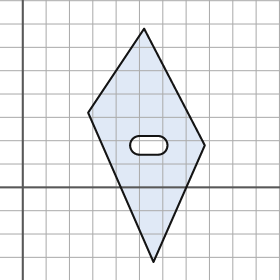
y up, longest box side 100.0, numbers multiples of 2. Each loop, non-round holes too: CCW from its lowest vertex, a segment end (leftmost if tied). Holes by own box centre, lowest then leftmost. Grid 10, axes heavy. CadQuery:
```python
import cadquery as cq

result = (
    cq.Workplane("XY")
    .moveTo(56.0, -32.0)
    .lineTo(78.0, 18.0)
    .lineTo(52.0, 68.0)
    .lineTo(28.0, 32.0)
    .close()
    .moveTo(50.0, 14.0)
    .lineTo(58.0, 14.0)
    .threePointArc((62.0, 18.0), (58.0, 22.0))
    .lineTo(50.0, 22.0)
    .threePointArc((46.0, 18.0), (50.0, 14.0))
    .close()
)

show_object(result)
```